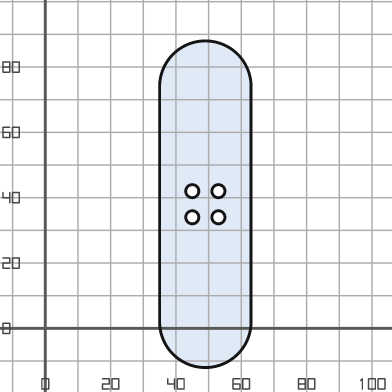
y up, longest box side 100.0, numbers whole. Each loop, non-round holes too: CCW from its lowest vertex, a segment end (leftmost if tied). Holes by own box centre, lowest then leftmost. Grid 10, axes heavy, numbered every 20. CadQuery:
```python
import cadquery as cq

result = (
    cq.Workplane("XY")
    .moveTo(35.0, 2.0)
    .threePointArc((49.0, -12.0), (63.0, 2.0))
    .lineTo(63.0, 74.0)
    .threePointArc((49.0, 88.0), (35.0, 74.0))
    .close()
    .moveTo(45.0, 34.0)
    .circle(2.0)
    .moveTo(53.0, 34.0)
    .circle(2.0)
    .moveTo(45.0, 42.0)
    .circle(2.0)
    .moveTo(53.0, 42.0)
    .circle(2.0)
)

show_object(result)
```